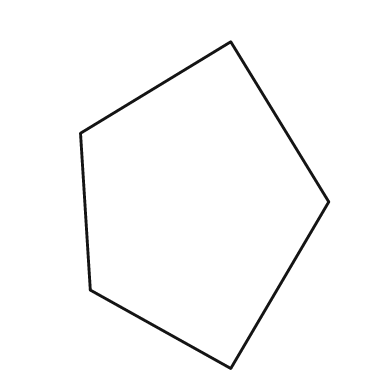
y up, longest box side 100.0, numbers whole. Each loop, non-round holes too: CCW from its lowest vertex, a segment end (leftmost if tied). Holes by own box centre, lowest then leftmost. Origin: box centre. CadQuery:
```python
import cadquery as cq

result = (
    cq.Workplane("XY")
    .moveTo(8.0, -50.0)
    .lineTo(38.0, 1.0)
    .lineTo(8.0, 50.0)
    .lineTo(-38.0, 22.0)
    .lineTo(-35.0, -26.0)
    .close()
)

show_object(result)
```